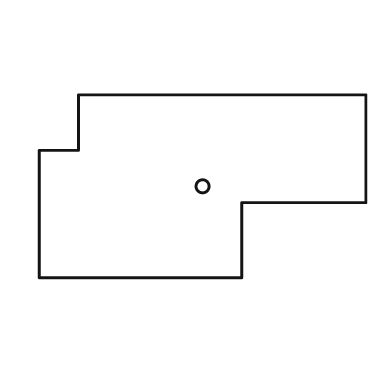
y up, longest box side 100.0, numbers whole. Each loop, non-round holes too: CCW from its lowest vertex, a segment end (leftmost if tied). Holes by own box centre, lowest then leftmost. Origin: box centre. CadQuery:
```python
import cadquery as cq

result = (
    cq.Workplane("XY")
    .moveTo(-50.0, -28.0)
    .lineTo(12.0, -28.0)
    .lineTo(12.0, -5.0)
    .lineTo(50.0, -5.0)
    .lineTo(50.0, 28.0)
    .lineTo(-38.0, 28.0)
    .lineTo(-38.0, 11.0)
    .lineTo(-50.0, 11.0)
    .close()
    .moveTo(0.0, 0.0)
    .circle(2.0)
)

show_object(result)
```